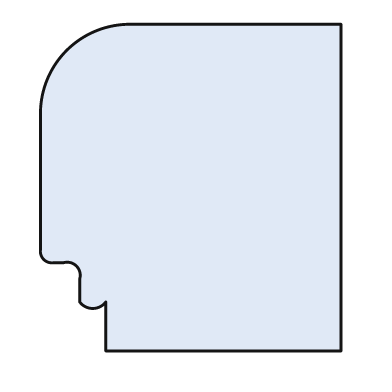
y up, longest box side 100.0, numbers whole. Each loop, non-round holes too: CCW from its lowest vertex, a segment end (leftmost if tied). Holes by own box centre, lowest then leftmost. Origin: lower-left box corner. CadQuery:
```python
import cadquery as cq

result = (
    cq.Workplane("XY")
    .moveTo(20.0, 0.0)
    .lineTo(92.0, 0.0)
    .lineTo(92.0, 100.0)
    .lineTo(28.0, 100.0)
    .threePointArc((8.0, 92.0), (0.0, 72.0))
    .lineTo(0.0, 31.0)
    .threePointArc((1.0, 28.0), (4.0, 27.0))
    .lineTo(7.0, 27.0)
    .threePointArc((11.0, 26.0), (12.0, 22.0))
    .lineTo(12.0, 15.0)
    .threePointArc((16.0, 13.0), (20.0, 15.0))
    .close()
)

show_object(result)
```